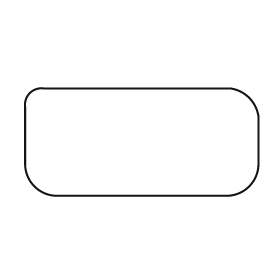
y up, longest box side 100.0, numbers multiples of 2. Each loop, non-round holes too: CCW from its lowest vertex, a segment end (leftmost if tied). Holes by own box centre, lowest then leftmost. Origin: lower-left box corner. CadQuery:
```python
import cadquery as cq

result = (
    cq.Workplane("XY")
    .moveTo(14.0, 0.0)
    .lineTo(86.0, 0.0)
    .threePointArc((96.0, 4.0), (100.0, 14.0))
    .lineTo(100.0, 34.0)
    .threePointArc((96.0, 42.0), (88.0, 46.0))
    .lineTo(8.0, 46.0)
    .threePointArc((2.0, 44.0), (0.0, 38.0))
    .lineTo(0.0, 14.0)
    .threePointArc((4.0, 4.0), (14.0, 0.0))
    .close()
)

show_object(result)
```